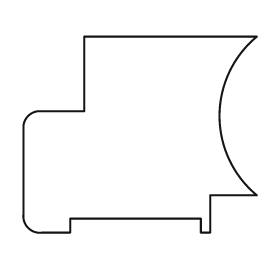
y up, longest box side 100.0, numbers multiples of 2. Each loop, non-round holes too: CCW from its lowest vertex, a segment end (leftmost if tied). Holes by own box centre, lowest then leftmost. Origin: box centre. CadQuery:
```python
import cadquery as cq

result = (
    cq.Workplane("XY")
    .moveTo(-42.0, -42.0)
    .lineTo(-30.0, -42.0)
    .lineTo(-30.0, -36.0)
    .lineTo(26.0, -36.0)
    .lineTo(26.0, -42.0)
    .lineTo(30.0, -42.0)
    .lineTo(30.0, -26.0)
    .lineTo(50.0, -26.0)
    .threePointArc((34.0, 8.0), (50.0, 42.0))
    .lineTo(-24.0, 42.0)
    .lineTo(-24.0, 10.0)
    .lineTo(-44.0, 10.0)
    .threePointArc((-48.0, 8.0), (-50.0, 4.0))
    .lineTo(-50.0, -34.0)
    .threePointArc((-48.0, -40.0), (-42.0, -42.0))
    .close()
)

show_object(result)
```